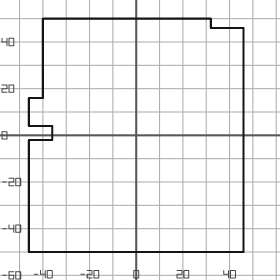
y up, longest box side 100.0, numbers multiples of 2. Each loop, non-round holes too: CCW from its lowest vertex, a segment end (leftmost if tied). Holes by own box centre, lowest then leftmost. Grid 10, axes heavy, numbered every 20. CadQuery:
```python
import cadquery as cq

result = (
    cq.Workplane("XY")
    .moveTo(-46.0, -50.0)
    .lineTo(46.0, -50.0)
    .lineTo(46.0, 46.0)
    .lineTo(32.0, 46.0)
    .lineTo(32.0, 50.0)
    .lineTo(-40.0, 50.0)
    .lineTo(-40.0, 16.0)
    .lineTo(-46.0, 16.0)
    .lineTo(-46.0, 4.0)
    .lineTo(-36.0, 4.0)
    .lineTo(-36.0, -2.0)
    .lineTo(-46.0, -2.0)
    .close()
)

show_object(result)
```